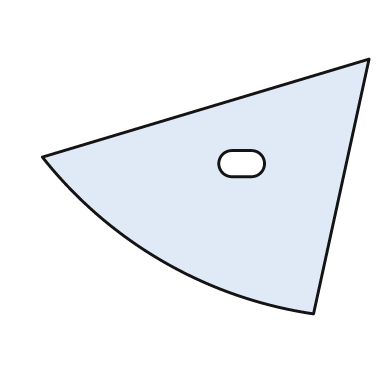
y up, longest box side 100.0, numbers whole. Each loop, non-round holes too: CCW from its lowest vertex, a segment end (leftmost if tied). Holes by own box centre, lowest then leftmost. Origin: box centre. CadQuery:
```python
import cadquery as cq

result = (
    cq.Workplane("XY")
    .moveTo(33.0, -39.0)
    .lineTo(50.0, 39.0)
    .lineTo(-50.0, 9.0)
    .threePointArc((-13.0, -23.0), (33.0, -39.0))
    .close()
    .moveTo(8.0, 3.0)
    .lineTo(14.0, 3.0)
    .threePointArc((18.0, 7.0), (14.0, 11.0))
    .lineTo(8.0, 11.0)
    .threePointArc((4.0, 7.0), (8.0, 3.0))
    .close()
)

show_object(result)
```